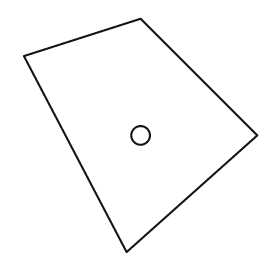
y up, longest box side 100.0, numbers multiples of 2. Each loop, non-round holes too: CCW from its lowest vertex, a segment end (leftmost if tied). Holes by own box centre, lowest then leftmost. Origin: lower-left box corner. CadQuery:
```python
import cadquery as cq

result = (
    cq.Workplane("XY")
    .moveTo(44.0, 0.0)
    .lineTo(100.0, 50.0)
    .lineTo(50.0, 100.0)
    .lineTo(0.0, 84.0)
    .close()
    .moveTo(50.0, 50.0)
    .circle(4.0)
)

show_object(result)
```